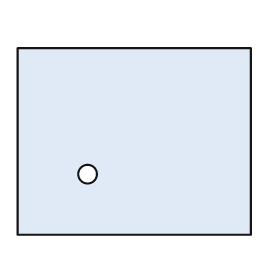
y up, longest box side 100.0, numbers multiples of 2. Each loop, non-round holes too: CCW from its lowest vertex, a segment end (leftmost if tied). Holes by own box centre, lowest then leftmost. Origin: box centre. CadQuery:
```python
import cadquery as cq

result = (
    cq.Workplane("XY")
    .moveTo(-50.0, -40.0)
    .lineTo(50.0, -40.0)
    .lineTo(50.0, 40.0)
    .lineTo(-50.0, 40.0)
    .close()
    .moveTo(-20.0, -14.0)
    .circle(4.0)
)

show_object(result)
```